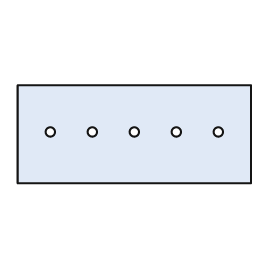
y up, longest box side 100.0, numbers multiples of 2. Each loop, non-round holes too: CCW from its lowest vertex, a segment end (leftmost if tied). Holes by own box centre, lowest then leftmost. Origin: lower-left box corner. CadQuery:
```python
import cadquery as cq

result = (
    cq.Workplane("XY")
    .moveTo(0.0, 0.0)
    .lineTo(100.0, 0.0)
    .lineTo(100.0, 42.0)
    .lineTo(0.0, 42.0)
    .close()
    .moveTo(14.0, 22.0)
    .circle(2.0)
    .moveTo(32.0, 22.0)
    .circle(2.0)
    .moveTo(50.0, 22.0)
    .circle(2.0)
    .moveTo(68.0, 22.0)
    .circle(2.0)
    .moveTo(86.0, 22.0)
    .circle(2.0)
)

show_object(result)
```